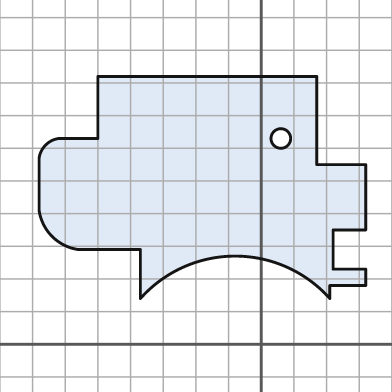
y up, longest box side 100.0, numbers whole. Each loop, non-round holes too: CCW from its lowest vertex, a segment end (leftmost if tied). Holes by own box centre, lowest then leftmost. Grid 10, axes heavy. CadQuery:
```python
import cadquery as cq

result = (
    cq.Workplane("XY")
    .moveTo(-37.0, 14.0)
    .threePointArc((-8.0, 27.0), (21.0, 14.0))
    .lineTo(21.0, 18.0)
    .lineTo(32.0, 18.0)
    .lineTo(32.0, 23.0)
    .lineTo(22.0, 23.0)
    .lineTo(22.0, 35.0)
    .lineTo(32.0, 35.0)
    .lineTo(32.0, 55.0)
    .lineTo(17.0, 55.0)
    .lineTo(17.0, 82.0)
    .lineTo(-50.0, 82.0)
    .lineTo(-50.0, 63.0)
    .lineTo(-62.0, 63.0)
    .threePointArc((-66.0, 61.0), (-68.0, 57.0))
    .lineTo(-68.0, 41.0)
    .threePointArc((-64.0, 33.0), (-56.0, 29.0))
    .lineTo(-37.0, 29.0)
    .close()
    .moveTo(6.0, 63.0)
    .circle(3.0)
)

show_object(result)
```